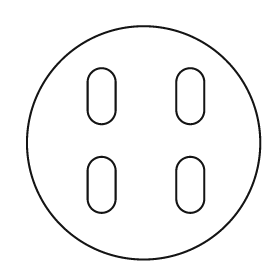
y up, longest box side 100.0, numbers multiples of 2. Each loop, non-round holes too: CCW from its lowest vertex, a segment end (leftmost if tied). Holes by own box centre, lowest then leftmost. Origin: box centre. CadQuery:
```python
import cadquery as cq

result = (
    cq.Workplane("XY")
    .moveTo(0.0, 0.0)
    .circle(50.0)
    .moveTo(-24.0, -24.0)
    .threePointArc((-18.0, -30.0), (-12.0, -24.0))
    .lineTo(-12.0, -12.0)
    .threePointArc((-18.0, -6.0), (-24.0, -12.0))
    .close()
    .moveTo(14.0, -24.0)
    .threePointArc((20.0, -30.0), (26.0, -24.0))
    .lineTo(26.0, -12.0)
    .threePointArc((20.0, -6.0), (14.0, -12.0))
    .close()
    .moveTo(-24.0, 14.0)
    .threePointArc((-18.0, 8.0), (-12.0, 14.0))
    .lineTo(-12.0, 26.0)
    .threePointArc((-18.0, 32.0), (-24.0, 26.0))
    .close()
    .moveTo(14.0, 14.0)
    .threePointArc((20.0, 8.0), (26.0, 14.0))
    .lineTo(26.0, 26.0)
    .threePointArc((20.0, 32.0), (14.0, 26.0))
    .close()
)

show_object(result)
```